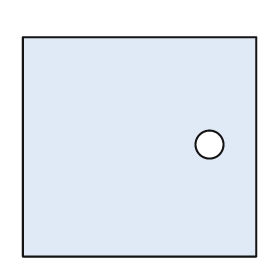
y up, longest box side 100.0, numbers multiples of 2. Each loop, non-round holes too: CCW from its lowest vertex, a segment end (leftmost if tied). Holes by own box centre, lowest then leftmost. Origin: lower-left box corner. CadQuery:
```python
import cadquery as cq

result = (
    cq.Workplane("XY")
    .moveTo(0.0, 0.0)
    .lineTo(100.0, 0.0)
    .lineTo(100.0, 94.0)
    .lineTo(0.0, 94.0)
    .close()
    .moveTo(80.0, 48.0)
    .circle(6.0)
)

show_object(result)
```